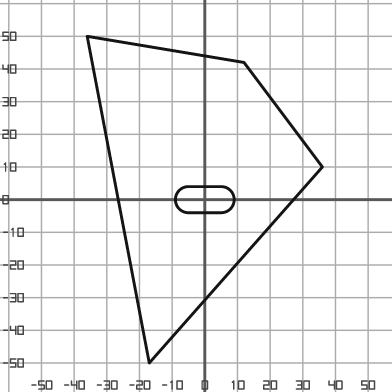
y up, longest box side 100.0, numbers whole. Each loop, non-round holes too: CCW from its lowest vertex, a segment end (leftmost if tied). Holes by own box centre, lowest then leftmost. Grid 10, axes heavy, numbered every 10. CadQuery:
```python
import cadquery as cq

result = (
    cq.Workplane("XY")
    .moveTo(-17.0, -50.0)
    .lineTo(36.0, 10.0)
    .lineTo(12.0, 42.0)
    .lineTo(-36.0, 50.0)
    .close()
    .moveTo(-5.0, -4.0)
    .lineTo(5.0, -4.0)
    .threePointArc((9.0, 0.0), (5.0, 4.0))
    .lineTo(-5.0, 4.0)
    .threePointArc((-9.0, 0.0), (-5.0, -4.0))
    .close()
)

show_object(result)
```